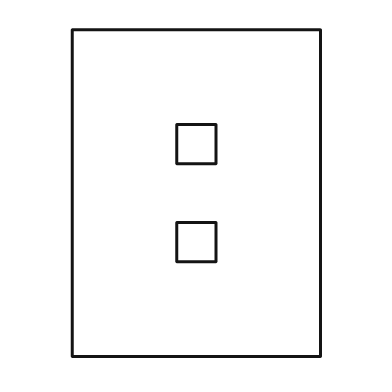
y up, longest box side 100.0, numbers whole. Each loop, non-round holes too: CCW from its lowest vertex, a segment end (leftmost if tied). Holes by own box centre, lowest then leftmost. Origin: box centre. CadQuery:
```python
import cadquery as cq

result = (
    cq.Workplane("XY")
    .moveTo(-38.0, -50.0)
    .lineTo(38.0, -50.0)
    .lineTo(38.0, 50.0)
    .lineTo(-38.0, 50.0)
    .close()
    .moveTo(-6.0, -21.0)
    .lineTo(6.0, -21.0)
    .lineTo(6.0, -9.0)
    .lineTo(-6.0, -9.0)
    .close()
    .moveTo(-6.0, 9.0)
    .lineTo(6.0, 9.0)
    .lineTo(6.0, 21.0)
    .lineTo(-6.0, 21.0)
    .close()
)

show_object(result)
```